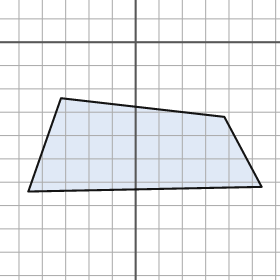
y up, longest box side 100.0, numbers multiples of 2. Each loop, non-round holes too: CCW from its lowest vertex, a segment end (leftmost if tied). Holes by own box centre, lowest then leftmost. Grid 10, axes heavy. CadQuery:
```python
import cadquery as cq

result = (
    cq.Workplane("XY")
    .moveTo(-46.0, -64.0)
    .lineTo(54.0, -62.0)
    .lineTo(38.0, -32.0)
    .lineTo(-32.0, -24.0)
    .close()
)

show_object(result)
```